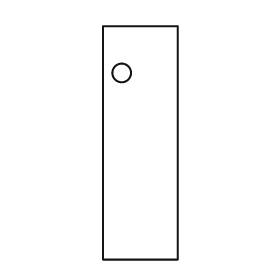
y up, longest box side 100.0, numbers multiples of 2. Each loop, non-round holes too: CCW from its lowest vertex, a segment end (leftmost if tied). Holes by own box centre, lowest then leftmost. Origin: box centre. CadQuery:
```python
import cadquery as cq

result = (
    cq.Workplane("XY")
    .moveTo(-16.0, -50.0)
    .lineTo(16.0, -50.0)
    .lineTo(16.0, 50.0)
    .lineTo(-16.0, 50.0)
    .close()
    .moveTo(-8.0, 30.0)
    .circle(4.0)
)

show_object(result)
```